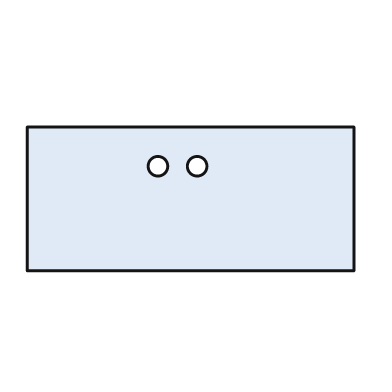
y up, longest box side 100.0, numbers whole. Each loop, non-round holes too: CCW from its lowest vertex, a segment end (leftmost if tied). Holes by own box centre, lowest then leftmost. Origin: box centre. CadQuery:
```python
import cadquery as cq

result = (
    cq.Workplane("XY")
    .moveTo(-50.0, -22.0)
    .lineTo(50.0, -22.0)
    .lineTo(50.0, 22.0)
    .lineTo(-50.0, 22.0)
    .close()
    .moveTo(-10.0, 10.0)
    .circle(3.0)
    .moveTo(2.0, 10.0)
    .circle(3.0)
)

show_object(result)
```